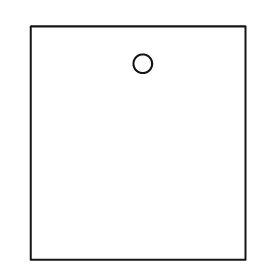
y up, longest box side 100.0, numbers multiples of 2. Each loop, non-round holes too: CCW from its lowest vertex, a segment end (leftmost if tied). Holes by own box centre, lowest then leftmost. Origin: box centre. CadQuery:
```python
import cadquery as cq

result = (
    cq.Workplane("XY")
    .moveTo(-46.0, -50.0)
    .lineTo(46.0, -50.0)
    .lineTo(46.0, 50.0)
    .lineTo(-46.0, 50.0)
    .close()
    .moveTo(2.0, 34.0)
    .circle(4.0)
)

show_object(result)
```